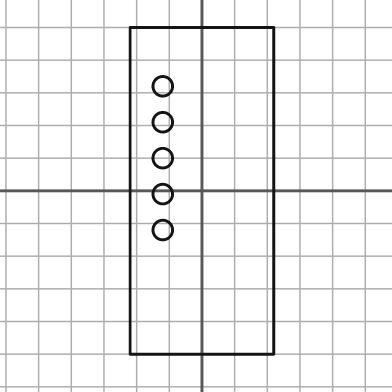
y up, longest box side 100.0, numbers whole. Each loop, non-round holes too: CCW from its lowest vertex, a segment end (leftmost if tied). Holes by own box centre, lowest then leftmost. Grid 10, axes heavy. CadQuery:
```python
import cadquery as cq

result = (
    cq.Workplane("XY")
    .moveTo(-22.0, -50.0)
    .lineTo(22.0, -50.0)
    .lineTo(22.0, 50.0)
    .lineTo(-22.0, 50.0)
    .close()
    .moveTo(-12.0, -12.0)
    .circle(3.0)
    .moveTo(-12.0, -1.0)
    .circle(3.0)
    .moveTo(-12.0, 10.0)
    .circle(3.0)
    .moveTo(-12.0, 21.0)
    .circle(3.0)
    .moveTo(-12.0, 32.0)
    .circle(3.0)
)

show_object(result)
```